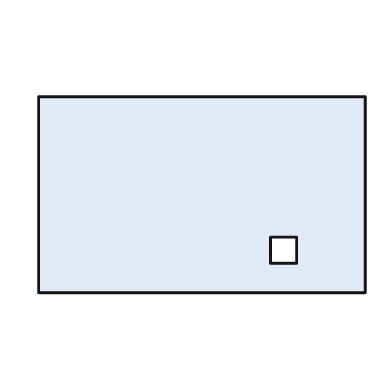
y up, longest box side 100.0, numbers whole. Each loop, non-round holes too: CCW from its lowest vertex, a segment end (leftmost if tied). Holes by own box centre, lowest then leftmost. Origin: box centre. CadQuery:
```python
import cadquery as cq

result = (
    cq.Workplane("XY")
    .moveTo(-50.0, -30.0)
    .lineTo(50.0, -30.0)
    .lineTo(50.0, 30.0)
    .lineTo(-50.0, 30.0)
    .close()
    .moveTo(21.0, -21.0)
    .lineTo(29.0, -21.0)
    .lineTo(29.0, -13.0)
    .lineTo(21.0, -13.0)
    .close()
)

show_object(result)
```